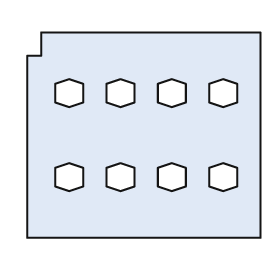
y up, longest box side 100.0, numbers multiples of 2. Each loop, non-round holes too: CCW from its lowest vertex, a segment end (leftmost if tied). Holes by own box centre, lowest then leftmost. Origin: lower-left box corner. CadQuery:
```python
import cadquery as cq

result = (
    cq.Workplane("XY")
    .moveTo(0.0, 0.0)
    .lineTo(100.0, 0.0)
    .lineTo(100.0, 88.0)
    .lineTo(6.0, 88.0)
    .lineTo(6.0, 78.0)
    .lineTo(0.0, 78.0)
    .close()
    .moveTo(18.0, 20.0)
    .lineTo(24.0, 22.0)
    .lineTo(24.0, 30.0)
    .lineTo(18.0, 32.0)
    .lineTo(12.0, 30.0)
    .lineTo(12.0, 22.0)
    .close()
    .moveTo(40.0, 20.0)
    .lineTo(46.0, 22.0)
    .lineTo(46.0, 30.0)
    .lineTo(40.0, 32.0)
    .lineTo(34.0, 30.0)
    .lineTo(34.0, 22.0)
    .close()
    .moveTo(62.0, 20.0)
    .lineTo(68.0, 22.0)
    .lineTo(68.0, 30.0)
    .lineTo(62.0, 32.0)
    .lineTo(56.0, 30.0)
    .lineTo(56.0, 22.0)
    .close()
    .moveTo(84.0, 20.0)
    .lineTo(90.0, 22.0)
    .lineTo(90.0, 30.0)
    .lineTo(84.0, 32.0)
    .lineTo(78.0, 30.0)
    .lineTo(78.0, 22.0)
    .close()
    .moveTo(18.0, 56.0)
    .lineTo(24.0, 58.0)
    .lineTo(24.0, 66.0)
    .lineTo(18.0, 68.0)
    .lineTo(12.0, 66.0)
    .lineTo(12.0, 58.0)
    .close()
    .moveTo(40.0, 56.0)
    .lineTo(46.0, 58.0)
    .lineTo(46.0, 66.0)
    .lineTo(40.0, 68.0)
    .lineTo(34.0, 66.0)
    .lineTo(34.0, 58.0)
    .close()
    .moveTo(62.0, 56.0)
    .lineTo(68.0, 58.0)
    .lineTo(68.0, 66.0)
    .lineTo(62.0, 68.0)
    .lineTo(56.0, 66.0)
    .lineTo(56.0, 58.0)
    .close()
    .moveTo(84.0, 56.0)
    .lineTo(90.0, 58.0)
    .lineTo(90.0, 66.0)
    .lineTo(84.0, 68.0)
    .lineTo(78.0, 66.0)
    .lineTo(78.0, 58.0)
    .close()
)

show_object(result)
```